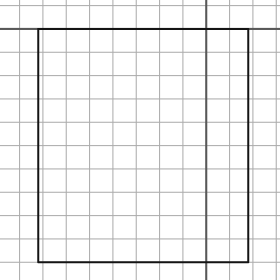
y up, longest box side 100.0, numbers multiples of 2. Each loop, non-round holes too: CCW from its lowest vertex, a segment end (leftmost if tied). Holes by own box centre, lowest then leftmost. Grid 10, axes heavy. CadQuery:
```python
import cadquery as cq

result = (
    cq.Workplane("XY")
    .moveTo(-72.0, -100.0)
    .lineTo(18.0, -100.0)
    .lineTo(18.0, 0.0)
    .lineTo(-72.0, 0.0)
    .close()
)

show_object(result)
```